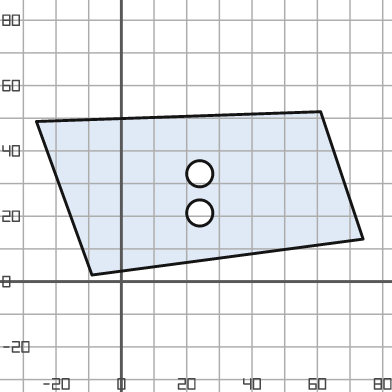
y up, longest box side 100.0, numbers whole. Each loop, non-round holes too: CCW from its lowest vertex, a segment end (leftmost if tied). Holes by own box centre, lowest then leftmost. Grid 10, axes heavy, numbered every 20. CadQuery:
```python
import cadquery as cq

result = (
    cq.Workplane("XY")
    .moveTo(-9.0, 2.0)
    .lineTo(74.0, 13.0)
    .lineTo(61.0, 52.0)
    .lineTo(-26.0, 49.0)
    .close()
    .moveTo(24.0, 21.0)
    .circle(4.0)
    .moveTo(24.0, 33.0)
    .circle(4.0)
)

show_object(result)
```